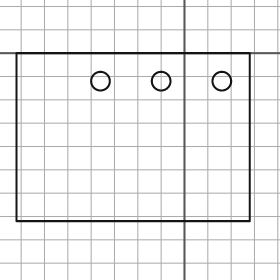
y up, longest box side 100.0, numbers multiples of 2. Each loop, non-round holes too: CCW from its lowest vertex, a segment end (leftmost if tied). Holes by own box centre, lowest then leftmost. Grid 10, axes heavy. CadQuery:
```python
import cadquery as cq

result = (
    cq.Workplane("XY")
    .moveTo(-72.0, -72.0)
    .lineTo(28.0, -72.0)
    .lineTo(28.0, 0.0)
    .lineTo(-72.0, 0.0)
    .close()
    .moveTo(-36.0, -12.0)
    .circle(4.0)
    .moveTo(-10.0, -12.0)
    .circle(4.0)
    .moveTo(16.0, -12.0)
    .circle(4.0)
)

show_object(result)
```